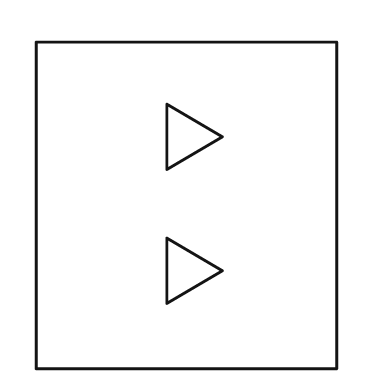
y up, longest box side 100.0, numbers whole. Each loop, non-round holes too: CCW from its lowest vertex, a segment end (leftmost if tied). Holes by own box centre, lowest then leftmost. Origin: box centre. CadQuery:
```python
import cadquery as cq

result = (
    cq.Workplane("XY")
    .moveTo(-46.0, -50.0)
    .lineTo(46.0, -50.0)
    .lineTo(46.0, 50.0)
    .lineTo(-46.0, 50.0)
    .close()
    .moveTo(-6.0, -30.0)
    .lineTo(11.0, -20.0)
    .lineTo(-6.0, -10.0)
    .close()
    .moveTo(-6.0, 11.0)
    .lineTo(11.0, 21.0)
    .lineTo(-6.0, 31.0)
    .close()
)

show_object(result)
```